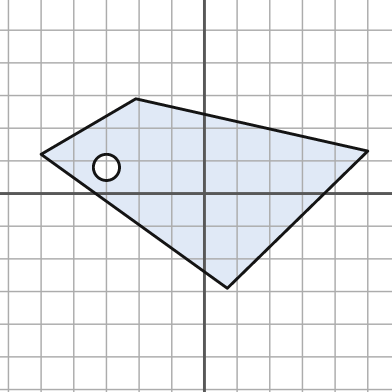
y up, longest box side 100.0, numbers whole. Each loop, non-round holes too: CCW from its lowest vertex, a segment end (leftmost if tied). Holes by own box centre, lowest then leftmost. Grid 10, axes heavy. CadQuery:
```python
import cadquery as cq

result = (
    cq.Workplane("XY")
    .moveTo(7.0, -29.0)
    .lineTo(50.0, 13.0)
    .lineTo(-21.0, 29.0)
    .lineTo(-50.0, 12.0)
    .close()
    .moveTo(-30.0, 8.0)
    .circle(4.0)
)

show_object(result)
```